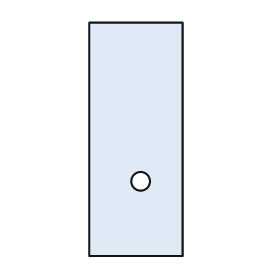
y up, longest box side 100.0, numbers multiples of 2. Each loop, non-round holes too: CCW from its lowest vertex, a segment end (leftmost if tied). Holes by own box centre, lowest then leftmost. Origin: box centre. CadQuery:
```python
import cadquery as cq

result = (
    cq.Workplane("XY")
    .moveTo(-20.0, -50.0)
    .lineTo(20.0, -50.0)
    .lineTo(20.0, 50.0)
    .lineTo(-20.0, 50.0)
    .close()
    .moveTo(2.0, -18.0)
    .circle(4.0)
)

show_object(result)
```